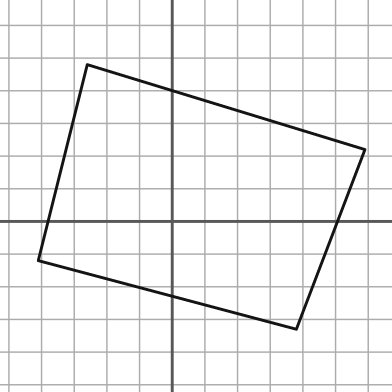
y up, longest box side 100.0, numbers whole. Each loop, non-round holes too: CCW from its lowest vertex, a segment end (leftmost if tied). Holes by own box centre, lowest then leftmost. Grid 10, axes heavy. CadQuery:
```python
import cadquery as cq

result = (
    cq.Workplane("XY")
    .moveTo(38.0, -33.0)
    .lineTo(59.0, 22.0)
    .lineTo(-26.0, 48.0)
    .lineTo(-41.0, -12.0)
    .close()
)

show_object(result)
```